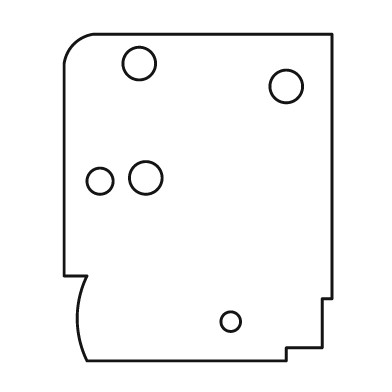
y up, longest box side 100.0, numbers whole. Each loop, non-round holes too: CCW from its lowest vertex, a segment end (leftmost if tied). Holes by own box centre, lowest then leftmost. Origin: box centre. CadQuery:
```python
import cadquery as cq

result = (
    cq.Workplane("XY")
    .moveTo(-34.0, -50.0)
    .lineTo(27.0, -50.0)
    .lineTo(27.0, -46.0)
    .lineTo(38.0, -46.0)
    .lineTo(38.0, -31.0)
    .lineTo(41.0, -31.0)
    .lineTo(41.0, 50.0)
    .lineTo(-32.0, 50.0)
    .threePointArc((-38.0, 47.0), (-41.0, 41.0))
    .lineTo(-41.0, -24.0)
    .lineTo(-34.0, -24.0)
    .threePointArc((-37.0, -37.0), (-34.0, -50.0))
    .close()
    .moveTo(10.0, -38.0)
    .circle(3.0)
    .moveTo(-30.0, 5.0)
    .circle(4.0)
    .moveTo(-16.0, 6.0)
    .circle(5.0)
    .moveTo(27.0, 34.0)
    .circle(5.0)
    .moveTo(-18.0, 41.0)
    .circle(5.0)
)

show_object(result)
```